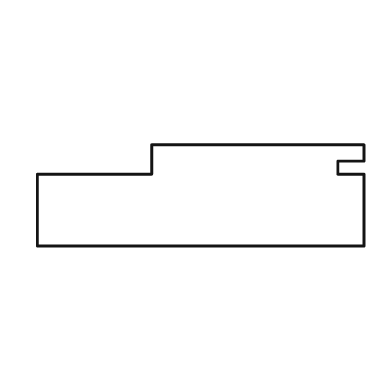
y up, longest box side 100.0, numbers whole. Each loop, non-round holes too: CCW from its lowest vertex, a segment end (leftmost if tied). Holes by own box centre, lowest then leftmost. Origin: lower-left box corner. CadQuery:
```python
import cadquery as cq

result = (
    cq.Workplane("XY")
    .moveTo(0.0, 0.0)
    .lineTo(100.0, 0.0)
    .lineTo(100.0, 22.0)
    .lineTo(92.0, 22.0)
    .lineTo(92.0, 26.0)
    .lineTo(100.0, 26.0)
    .lineTo(100.0, 31.0)
    .lineTo(35.0, 31.0)
    .lineTo(35.0, 22.0)
    .lineTo(0.0, 22.0)
    .close()
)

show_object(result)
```